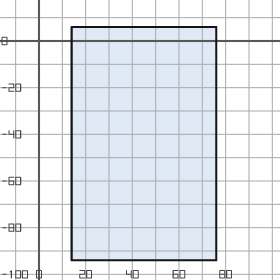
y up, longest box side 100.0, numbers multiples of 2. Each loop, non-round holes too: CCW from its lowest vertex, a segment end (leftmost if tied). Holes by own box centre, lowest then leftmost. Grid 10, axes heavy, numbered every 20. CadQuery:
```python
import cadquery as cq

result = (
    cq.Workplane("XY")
    .moveTo(14.0, -94.0)
    .lineTo(76.0, -94.0)
    .lineTo(76.0, 6.0)
    .lineTo(14.0, 6.0)
    .close()
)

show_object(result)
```